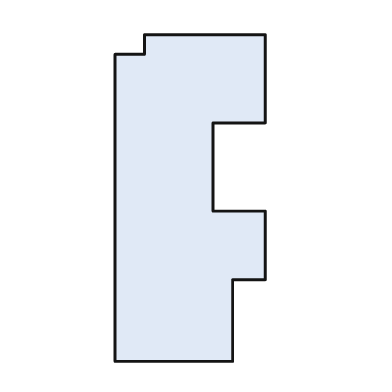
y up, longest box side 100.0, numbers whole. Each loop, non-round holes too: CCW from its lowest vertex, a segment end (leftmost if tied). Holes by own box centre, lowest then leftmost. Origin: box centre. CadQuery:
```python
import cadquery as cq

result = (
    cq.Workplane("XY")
    .moveTo(-23.0, -50.0)
    .lineTo(13.0, -50.0)
    .lineTo(13.0, -25.0)
    .lineTo(23.0, -25.0)
    .lineTo(23.0, -4.0)
    .lineTo(7.0, -4.0)
    .lineTo(7.0, 23.0)
    .lineTo(23.0, 23.0)
    .lineTo(23.0, 50.0)
    .lineTo(-14.0, 50.0)
    .lineTo(-14.0, 44.0)
    .lineTo(-23.0, 44.0)
    .close()
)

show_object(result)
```